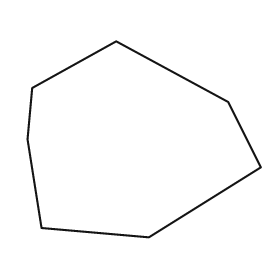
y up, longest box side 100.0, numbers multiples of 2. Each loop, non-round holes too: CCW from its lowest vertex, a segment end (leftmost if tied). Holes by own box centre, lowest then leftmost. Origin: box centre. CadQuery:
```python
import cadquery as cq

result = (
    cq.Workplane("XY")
    .moveTo(2.0, -42.0)
    .lineTo(50.0, -12.0)
    .lineTo(36.0, 16.0)
    .lineTo(-12.0, 42.0)
    .lineTo(-48.0, 22.0)
    .lineTo(-50.0, 0.0)
    .lineTo(-44.0, -38.0)
    .close()
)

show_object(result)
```